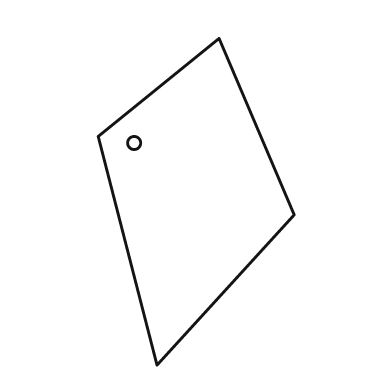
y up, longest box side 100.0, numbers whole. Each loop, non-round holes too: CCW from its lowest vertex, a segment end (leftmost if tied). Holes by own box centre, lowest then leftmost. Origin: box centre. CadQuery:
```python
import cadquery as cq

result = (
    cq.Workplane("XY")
    .moveTo(-12.0, -50.0)
    .lineTo(30.0, -4.0)
    .lineTo(7.0, 50.0)
    .lineTo(-30.0, 20.0)
    .close()
    .moveTo(-19.0, 18.0)
    .circle(2.0)
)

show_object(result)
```